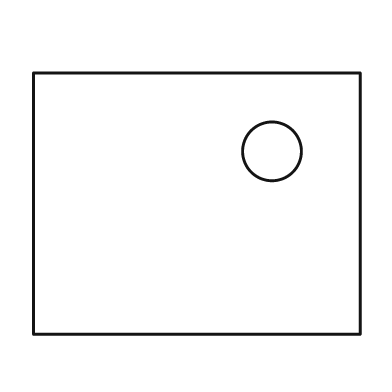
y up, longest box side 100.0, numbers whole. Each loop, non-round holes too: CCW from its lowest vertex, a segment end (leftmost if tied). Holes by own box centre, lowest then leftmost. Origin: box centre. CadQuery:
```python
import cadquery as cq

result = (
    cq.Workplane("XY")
    .moveTo(-50.0, -40.0)
    .lineTo(50.0, -40.0)
    .lineTo(50.0, 40.0)
    .lineTo(-50.0, 40.0)
    .close()
    .moveTo(23.0, 16.0)
    .circle(9.0)
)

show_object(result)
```